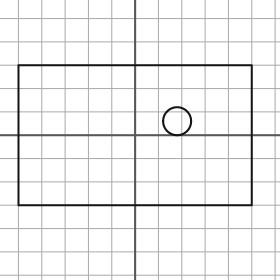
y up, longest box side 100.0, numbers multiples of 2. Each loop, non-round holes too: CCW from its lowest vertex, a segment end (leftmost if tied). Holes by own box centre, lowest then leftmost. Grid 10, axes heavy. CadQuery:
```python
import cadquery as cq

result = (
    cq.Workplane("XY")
    .moveTo(-50.0, -30.0)
    .lineTo(50.0, -30.0)
    .lineTo(50.0, 30.0)
    .lineTo(-50.0, 30.0)
    .close()
    .moveTo(18.0, 6.0)
    .circle(6.0)
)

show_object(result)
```